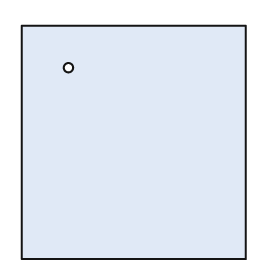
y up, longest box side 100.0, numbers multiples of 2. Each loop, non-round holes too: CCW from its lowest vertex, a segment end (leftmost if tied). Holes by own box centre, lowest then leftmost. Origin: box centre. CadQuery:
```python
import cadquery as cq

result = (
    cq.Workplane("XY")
    .moveTo(-48.0, -50.0)
    .lineTo(48.0, -50.0)
    .lineTo(48.0, 50.0)
    .lineTo(-48.0, 50.0)
    .close()
    .moveTo(-28.0, 32.0)
    .circle(2.0)
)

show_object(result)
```